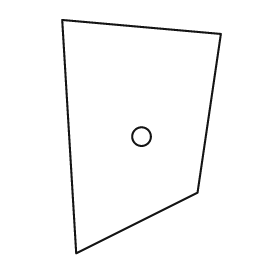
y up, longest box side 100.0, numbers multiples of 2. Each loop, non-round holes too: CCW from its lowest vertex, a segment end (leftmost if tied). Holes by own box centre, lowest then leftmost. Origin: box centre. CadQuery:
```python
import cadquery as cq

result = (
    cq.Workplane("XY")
    .moveTo(-28.0, -50.0)
    .lineTo(24.0, -24.0)
    .lineTo(34.0, 44.0)
    .lineTo(-34.0, 50.0)
    .close()
    .moveTo(0.0, 0.0)
    .circle(4.0)
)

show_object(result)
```